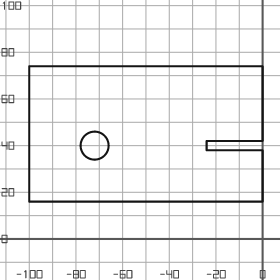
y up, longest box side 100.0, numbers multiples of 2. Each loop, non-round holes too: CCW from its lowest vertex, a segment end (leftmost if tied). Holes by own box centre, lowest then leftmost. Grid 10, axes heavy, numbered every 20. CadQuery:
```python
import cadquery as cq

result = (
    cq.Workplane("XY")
    .moveTo(-100.0, 16.0)
    .lineTo(0.0, 16.0)
    .lineTo(0.0, 38.0)
    .lineTo(-24.0, 38.0)
    .lineTo(-24.0, 42.0)
    .lineTo(0.0, 42.0)
    .lineTo(0.0, 74.0)
    .lineTo(-100.0, 74.0)
    .close()
    .moveTo(-72.0, 40.0)
    .circle(6.0)
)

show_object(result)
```